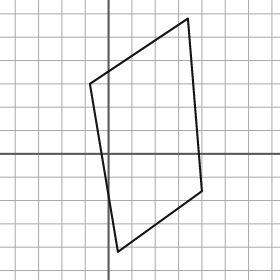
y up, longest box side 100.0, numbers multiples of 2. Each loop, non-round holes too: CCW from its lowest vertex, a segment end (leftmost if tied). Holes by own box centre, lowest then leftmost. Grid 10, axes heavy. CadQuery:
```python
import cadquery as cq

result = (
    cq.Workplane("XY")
    .moveTo(4.0, -42.0)
    .lineTo(40.0, -16.0)
    .lineTo(34.0, 58.0)
    .lineTo(-8.0, 30.0)
    .close()
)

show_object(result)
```